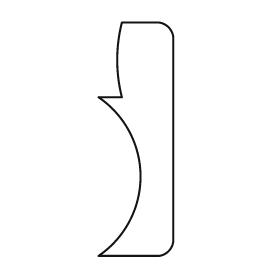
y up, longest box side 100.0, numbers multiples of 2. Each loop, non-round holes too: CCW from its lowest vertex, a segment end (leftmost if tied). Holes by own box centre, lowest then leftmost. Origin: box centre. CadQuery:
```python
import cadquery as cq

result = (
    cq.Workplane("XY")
    .moveTo(-16.0, -50.0)
    .lineTo(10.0, -50.0)
    .threePointArc((14.0, -48.0), (16.0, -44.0))
    .lineTo(16.0, 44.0)
    .threePointArc((14.0, 48.0), (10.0, 50.0))
    .lineTo(-6.0, 50.0)
    .threePointArc((-8.0, 34.0), (-6.0, 18.0))
    .lineTo(-16.0, 18.0)
    .threePointArc((2.0, -16.0), (-16.0, -50.0))
    .close()
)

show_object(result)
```